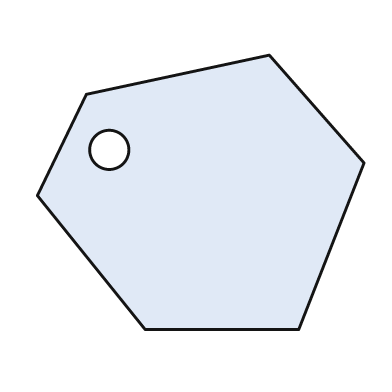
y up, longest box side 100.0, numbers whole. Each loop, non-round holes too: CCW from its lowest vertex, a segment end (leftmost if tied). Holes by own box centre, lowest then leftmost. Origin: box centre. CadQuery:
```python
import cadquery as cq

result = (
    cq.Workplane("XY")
    .moveTo(-17.0, -42.0)
    .lineTo(30.0, -42.0)
    .lineTo(50.0, 9.0)
    .lineTo(21.0, 42.0)
    .lineTo(-35.0, 30.0)
    .lineTo(-50.0, -1.0)
    .close()
    .moveTo(-28.0, 13.0)
    .circle(6.0)
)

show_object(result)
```